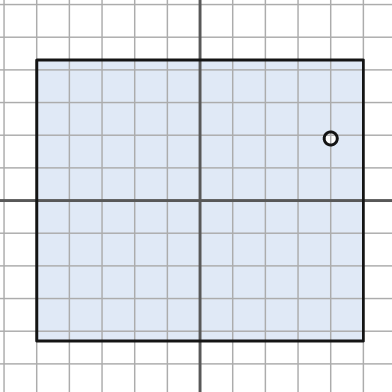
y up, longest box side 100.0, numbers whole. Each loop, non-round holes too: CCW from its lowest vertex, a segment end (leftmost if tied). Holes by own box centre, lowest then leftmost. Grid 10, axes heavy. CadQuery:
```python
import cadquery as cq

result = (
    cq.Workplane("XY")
    .moveTo(-50.0, -43.0)
    .lineTo(50.0, -43.0)
    .lineTo(50.0, 43.0)
    .lineTo(-50.0, 43.0)
    .close()
    .moveTo(40.0, 19.0)
    .circle(2.0)
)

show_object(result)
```